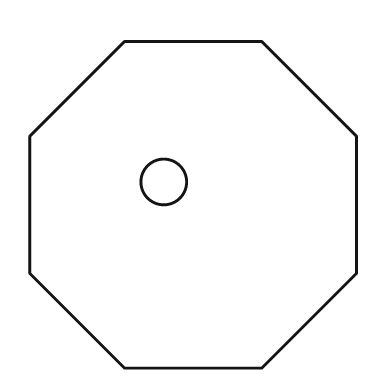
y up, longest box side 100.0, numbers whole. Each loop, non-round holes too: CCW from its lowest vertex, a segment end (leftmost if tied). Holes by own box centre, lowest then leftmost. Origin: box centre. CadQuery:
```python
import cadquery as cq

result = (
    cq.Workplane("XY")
    .moveTo(-21.0, -50.0)
    .lineTo(21.0, -50.0)
    .lineTo(50.0, -21.0)
    .lineTo(50.0, 21.0)
    .lineTo(21.0, 50.0)
    .lineTo(-21.0, 50.0)
    .lineTo(-50.0, 21.0)
    .lineTo(-50.0, -21.0)
    .close()
    .moveTo(-9.0, 7.0)
    .circle(7.0)
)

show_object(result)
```